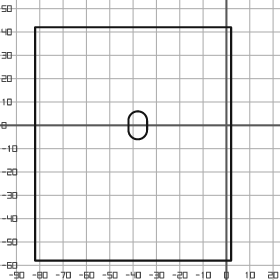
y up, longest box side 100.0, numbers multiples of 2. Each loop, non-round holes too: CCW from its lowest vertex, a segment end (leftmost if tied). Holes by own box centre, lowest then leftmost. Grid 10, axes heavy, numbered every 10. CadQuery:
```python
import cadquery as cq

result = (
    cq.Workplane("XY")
    .moveTo(-82.0, -58.0)
    .lineTo(2.0, -58.0)
    .lineTo(2.0, 42.0)
    .lineTo(-82.0, 42.0)
    .close()
    .moveTo(-42.0, -2.0)
    .threePointArc((-38.0, -6.0), (-34.0, -2.0))
    .lineTo(-34.0, 2.0)
    .threePointArc((-38.0, 6.0), (-42.0, 2.0))
    .close()
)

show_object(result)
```